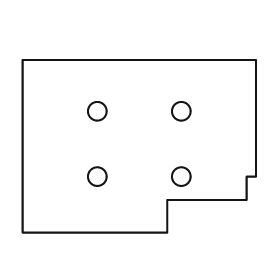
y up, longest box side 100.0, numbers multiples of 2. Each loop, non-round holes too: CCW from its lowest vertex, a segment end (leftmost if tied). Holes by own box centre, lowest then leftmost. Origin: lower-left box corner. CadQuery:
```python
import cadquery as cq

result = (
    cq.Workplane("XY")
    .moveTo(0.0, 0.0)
    .lineTo(62.0, 0.0)
    .lineTo(62.0, 14.0)
    .lineTo(96.0, 14.0)
    .lineTo(96.0, 24.0)
    .lineTo(100.0, 24.0)
    .lineTo(100.0, 74.0)
    .lineTo(0.0, 74.0)
    .close()
    .moveTo(32.0, 24.0)
    .circle(4.0)
    .moveTo(68.0, 24.0)
    .circle(4.0)
    .moveTo(32.0, 52.0)
    .circle(4.0)
    .moveTo(68.0, 52.0)
    .circle(4.0)
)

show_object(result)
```